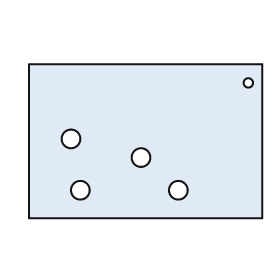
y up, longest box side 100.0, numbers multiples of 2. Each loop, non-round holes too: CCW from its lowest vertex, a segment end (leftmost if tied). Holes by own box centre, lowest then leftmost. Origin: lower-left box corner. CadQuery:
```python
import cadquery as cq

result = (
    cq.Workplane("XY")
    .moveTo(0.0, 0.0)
    .lineTo(100.0, 0.0)
    .lineTo(100.0, 66.0)
    .lineTo(0.0, 66.0)
    .close()
    .moveTo(22.0, 12.0)
    .circle(4.0)
    .moveTo(64.0, 12.0)
    .circle(4.0)
    .moveTo(48.0, 26.0)
    .circle(4.0)
    .moveTo(18.0, 34.0)
    .circle(4.0)
    .moveTo(94.0, 58.0)
    .circle(2.0)
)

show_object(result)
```